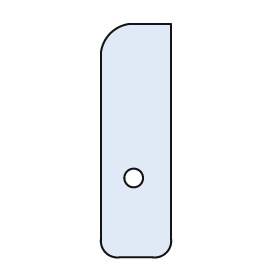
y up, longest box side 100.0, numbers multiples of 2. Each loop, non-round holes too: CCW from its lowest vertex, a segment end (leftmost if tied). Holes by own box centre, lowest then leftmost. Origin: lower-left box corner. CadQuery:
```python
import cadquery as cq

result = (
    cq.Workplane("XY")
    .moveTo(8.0, 0.0)
    .lineTo(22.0, 0.0)
    .threePointArc((28.0, 2.0), (30.0, 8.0))
    .lineTo(30.0, 100.0)
    .lineTo(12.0, 100.0)
    .threePointArc((4.0, 96.0), (0.0, 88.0))
    .lineTo(0.0, 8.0)
    .threePointArc((2.0, 2.0), (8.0, 0.0))
    .close()
    .moveTo(14.0, 34.0)
    .circle(4.0)
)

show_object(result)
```